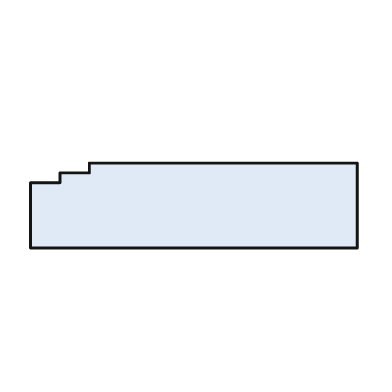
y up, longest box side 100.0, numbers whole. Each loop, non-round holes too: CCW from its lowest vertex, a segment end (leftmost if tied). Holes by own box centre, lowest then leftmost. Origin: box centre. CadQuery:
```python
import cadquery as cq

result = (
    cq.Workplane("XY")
    .moveTo(-50.0, -13.0)
    .lineTo(50.0, -13.0)
    .lineTo(50.0, 13.0)
    .lineTo(-32.0, 13.0)
    .lineTo(-32.0, 10.0)
    .lineTo(-41.0, 10.0)
    .lineTo(-41.0, 7.0)
    .lineTo(-50.0, 7.0)
    .close()
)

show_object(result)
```